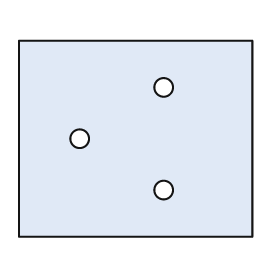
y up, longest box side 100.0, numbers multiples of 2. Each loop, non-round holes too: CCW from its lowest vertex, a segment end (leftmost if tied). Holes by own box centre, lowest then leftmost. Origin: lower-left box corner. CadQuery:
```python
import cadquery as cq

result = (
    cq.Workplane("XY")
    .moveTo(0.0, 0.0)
    .lineTo(100.0, 0.0)
    .lineTo(100.0, 84.0)
    .lineTo(0.0, 84.0)
    .close()
    .moveTo(62.0, 20.0)
    .circle(4.0)
    .moveTo(26.0, 42.0)
    .circle(4.0)
    .moveTo(62.0, 64.0)
    .circle(4.0)
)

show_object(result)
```